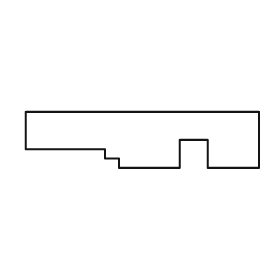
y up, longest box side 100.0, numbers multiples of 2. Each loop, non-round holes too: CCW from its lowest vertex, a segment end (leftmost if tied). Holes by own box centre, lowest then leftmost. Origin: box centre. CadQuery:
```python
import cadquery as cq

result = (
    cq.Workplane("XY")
    .moveTo(-10.0, -12.0)
    .lineTo(16.0, -12.0)
    .lineTo(16.0, 0.0)
    .lineTo(28.0, 0.0)
    .lineTo(28.0, -12.0)
    .lineTo(50.0, -12.0)
    .lineTo(50.0, 12.0)
    .lineTo(-50.0, 12.0)
    .lineTo(-50.0, -4.0)
    .lineTo(-16.0, -4.0)
    .lineTo(-16.0, -8.0)
    .lineTo(-10.0, -8.0)
    .close()
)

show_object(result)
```